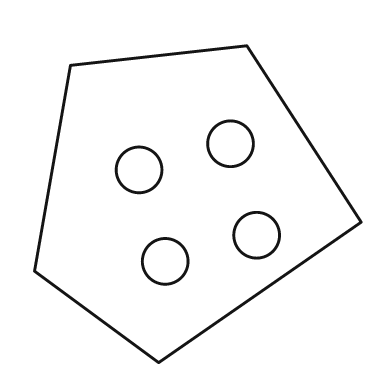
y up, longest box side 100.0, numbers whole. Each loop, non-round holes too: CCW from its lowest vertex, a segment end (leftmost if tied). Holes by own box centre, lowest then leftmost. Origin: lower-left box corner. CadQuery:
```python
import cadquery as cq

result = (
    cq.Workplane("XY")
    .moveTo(38.0, 0.0)
    .lineTo(100.0, 43.0)
    .lineTo(65.0, 97.0)
    .lineTo(11.0, 91.0)
    .lineTo(0.0, 28.0)
    .close()
    .moveTo(40.0, 31.0)
    .circle(7.0)
    .moveTo(68.0, 39.0)
    .circle(7.0)
    .moveTo(32.0, 59.0)
    .circle(7.0)
    .moveTo(60.0, 67.0)
    .circle(7.0)
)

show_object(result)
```